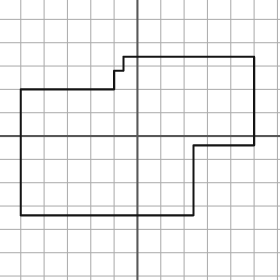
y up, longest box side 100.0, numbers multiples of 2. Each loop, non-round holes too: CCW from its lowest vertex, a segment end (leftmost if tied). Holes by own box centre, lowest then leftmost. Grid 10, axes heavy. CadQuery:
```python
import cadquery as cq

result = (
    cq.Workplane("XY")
    .moveTo(-50.0, -34.0)
    .lineTo(24.0, -34.0)
    .lineTo(24.0, -4.0)
    .lineTo(50.0, -4.0)
    .lineTo(50.0, 34.0)
    .lineTo(-6.0, 34.0)
    .lineTo(-6.0, 28.0)
    .lineTo(-10.0, 28.0)
    .lineTo(-10.0, 20.0)
    .lineTo(-50.0, 20.0)
    .close()
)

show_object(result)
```